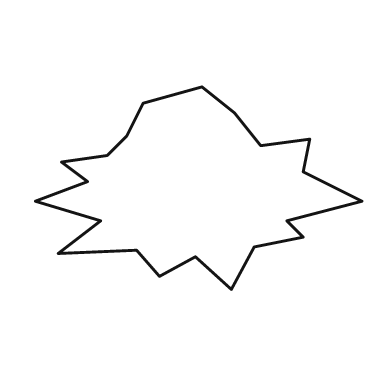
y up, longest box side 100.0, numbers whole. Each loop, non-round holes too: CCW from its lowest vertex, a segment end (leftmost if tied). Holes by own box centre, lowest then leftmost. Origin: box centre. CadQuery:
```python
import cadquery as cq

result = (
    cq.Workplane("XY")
    .moveTo(10.0, -31.0)
    .lineTo(17.0, -18.0)
    .lineTo(32.0, -15.0)
    .lineTo(27.0, -10.0)
    .lineTo(50.0, -4.0)
    .lineTo(32.0, 5.0)
    .lineTo(34.0, 15.0)
    .lineTo(19.0, 13.0)
    .lineTo(11.0, 23.0)
    .lineTo(1.0, 31.0)
    .lineTo(-17.0, 26.0)
    .lineTo(-22.0, 16.0)
    .lineTo(-28.0, 10.0)
    .lineTo(-42.0, 8.0)
    .lineTo(-34.0, 2.0)
    .lineTo(-50.0, -4.0)
    .lineTo(-30.0, -10.0)
    .lineTo(-43.0, -20.0)
    .lineTo(-19.0, -19.0)
    .lineTo(-12.0, -27.0)
    .lineTo(-1.0, -21.0)
    .close()
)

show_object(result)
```